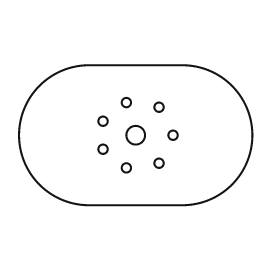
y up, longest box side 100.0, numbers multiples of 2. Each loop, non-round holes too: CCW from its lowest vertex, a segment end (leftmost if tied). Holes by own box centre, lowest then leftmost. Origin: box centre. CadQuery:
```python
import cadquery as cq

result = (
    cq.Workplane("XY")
    .moveTo(-20.0, -30.0)
    .lineTo(20.0, -30.0)
    .threePointArc((50.0, 0.0), (20.0, 30.0))
    .lineTo(-20.0, 30.0)
    .threePointArc((-50.0, 0.0), (-20.0, -30.0))
    .close()
    .moveTo(-4.0, -14.0)
    .circle(2.0)
    .moveTo(10.0, -12.0)
    .circle(2.0)
    .moveTo(-14.0, -6.0)
    .circle(2.0)
    .moveTo(0.0, 0.0)
    .circle(4.0)
    .moveTo(16.0, 0.0)
    .circle(2.0)
    .moveTo(-14.0, 6.0)
    .circle(2.0)
    .moveTo(10.0, 12.0)
    .circle(2.0)
    .moveTo(-4.0, 14.0)
    .circle(2.0)
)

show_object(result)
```